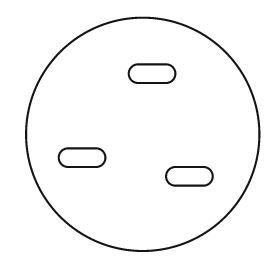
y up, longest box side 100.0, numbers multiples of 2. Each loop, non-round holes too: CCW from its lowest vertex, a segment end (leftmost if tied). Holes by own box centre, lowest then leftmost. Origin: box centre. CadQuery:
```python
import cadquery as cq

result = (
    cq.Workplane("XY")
    .moveTo(0.0, 0.0)
    .circle(50.0)
    .moveTo(14.0, -22.0)
    .lineTo(26.0, -22.0)
    .threePointArc((30.0, -18.0), (26.0, -14.0))
    .lineTo(14.0, -14.0)
    .threePointArc((10.0, -18.0), (14.0, -22.0))
    .close()
    .moveTo(-32.0, -14.0)
    .lineTo(-20.0, -14.0)
    .threePointArc((-16.0, -10.0), (-20.0, -6.0))
    .lineTo(-32.0, -6.0)
    .threePointArc((-36.0, -10.0), (-32.0, -14.0))
    .close()
    .moveTo(-2.0, 22.0)
    .lineTo(10.0, 22.0)
    .threePointArc((14.0, 26.0), (10.0, 30.0))
    .lineTo(-2.0, 30.0)
    .threePointArc((-6.0, 26.0), (-2.0, 22.0))
    .close()
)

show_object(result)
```